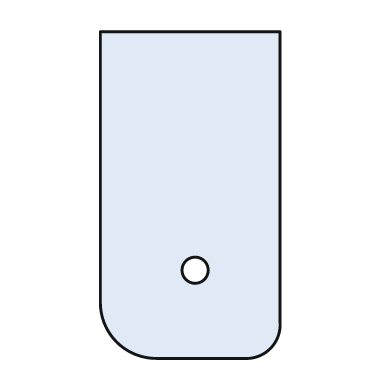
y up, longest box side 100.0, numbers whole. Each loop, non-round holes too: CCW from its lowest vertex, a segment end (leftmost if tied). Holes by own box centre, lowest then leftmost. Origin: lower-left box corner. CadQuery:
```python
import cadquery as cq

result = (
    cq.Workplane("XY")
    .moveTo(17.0, 0.0)
    .lineTo(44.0, 0.0)
    .threePointArc((52.0, 3.0), (55.0, 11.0))
    .lineTo(55.0, 100.0)
    .lineTo(0.0, 100.0)
    .lineTo(0.0, 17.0)
    .threePointArc((5.0, 5.0), (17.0, 0.0))
    .close()
    .moveTo(29.0, 27.0)
    .circle(4.0)
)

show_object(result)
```